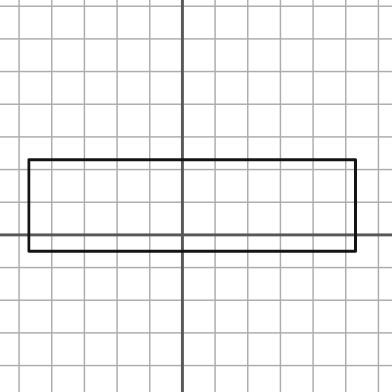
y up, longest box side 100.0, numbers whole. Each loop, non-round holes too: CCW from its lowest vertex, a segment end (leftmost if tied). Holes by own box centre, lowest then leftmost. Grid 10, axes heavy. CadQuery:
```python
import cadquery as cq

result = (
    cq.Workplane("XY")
    .moveTo(-47.0, -5.0)
    .lineTo(53.0, -5.0)
    .lineTo(53.0, 23.0)
    .lineTo(-47.0, 23.0)
    .close()
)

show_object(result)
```